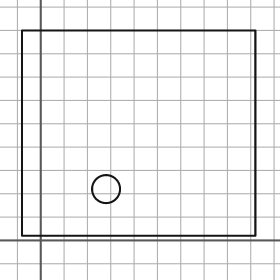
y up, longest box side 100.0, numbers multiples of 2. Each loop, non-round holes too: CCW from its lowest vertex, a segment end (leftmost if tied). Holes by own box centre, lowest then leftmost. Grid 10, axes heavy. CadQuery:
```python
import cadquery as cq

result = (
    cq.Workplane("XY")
    .moveTo(-8.0, 2.0)
    .lineTo(92.0, 2.0)
    .lineTo(92.0, 90.0)
    .lineTo(-8.0, 90.0)
    .close()
    .moveTo(28.0, 22.0)
    .circle(6.0)
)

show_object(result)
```